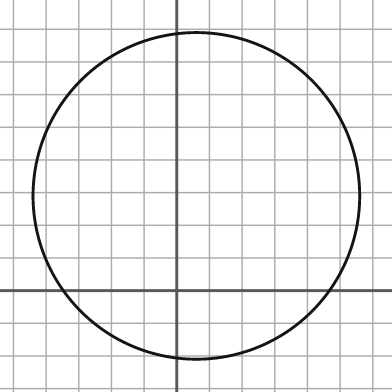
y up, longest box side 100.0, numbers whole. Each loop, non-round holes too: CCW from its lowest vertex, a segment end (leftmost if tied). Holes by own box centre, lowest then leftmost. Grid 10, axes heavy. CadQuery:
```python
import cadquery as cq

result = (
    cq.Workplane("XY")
    .moveTo(6.0, 29.0)
    .circle(50.0)
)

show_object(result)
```